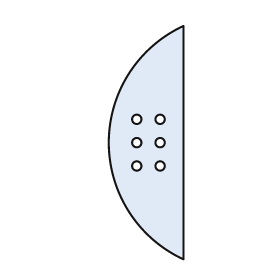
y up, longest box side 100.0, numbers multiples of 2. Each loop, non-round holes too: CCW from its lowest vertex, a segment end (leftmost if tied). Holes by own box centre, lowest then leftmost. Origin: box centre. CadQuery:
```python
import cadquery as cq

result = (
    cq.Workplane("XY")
    .moveTo(16.0, -50.0)
    .lineTo(16.0, 50.0)
    .threePointArc((-16.0, 0.0), (16.0, -50.0))
    .close()
    .moveTo(-4.0, -10.0)
    .circle(2.0)
    .moveTo(6.0, -10.0)
    .circle(2.0)
    .moveTo(-4.0, 0.0)
    .circle(2.0)
    .moveTo(6.0, 0.0)
    .circle(2.0)
    .moveTo(-4.0, 10.0)
    .circle(2.0)
    .moveTo(6.0, 10.0)
    .circle(2.0)
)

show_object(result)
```